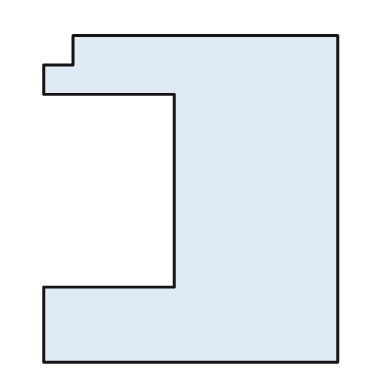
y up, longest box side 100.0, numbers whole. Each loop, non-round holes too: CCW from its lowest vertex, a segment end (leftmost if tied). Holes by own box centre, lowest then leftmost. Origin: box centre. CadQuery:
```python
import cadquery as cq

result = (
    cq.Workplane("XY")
    .moveTo(-45.0, -50.0)
    .lineTo(45.0, -50.0)
    .lineTo(45.0, 50.0)
    .lineTo(-36.0, 50.0)
    .lineTo(-36.0, 41.0)
    .lineTo(-45.0, 41.0)
    .lineTo(-45.0, 32.0)
    .lineTo(-5.0, 32.0)
    .lineTo(-5.0, -27.0)
    .lineTo(-45.0, -27.0)
    .close()
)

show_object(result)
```